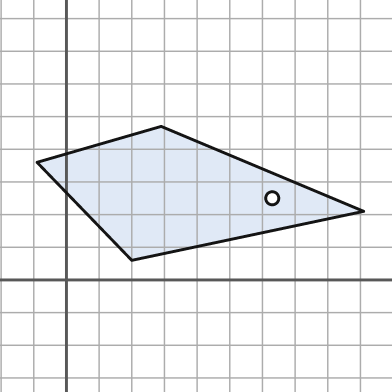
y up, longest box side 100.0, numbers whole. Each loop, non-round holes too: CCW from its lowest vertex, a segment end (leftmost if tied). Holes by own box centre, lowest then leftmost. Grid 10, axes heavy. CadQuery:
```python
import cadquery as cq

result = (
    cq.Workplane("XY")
    .moveTo(20.0, 6.0)
    .lineTo(91.0, 21.0)
    .lineTo(29.0, 47.0)
    .lineTo(-9.0, 36.0)
    .close()
    .moveTo(63.0, 25.0)
    .circle(2.0)
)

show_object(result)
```